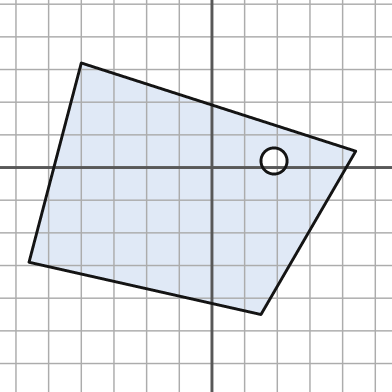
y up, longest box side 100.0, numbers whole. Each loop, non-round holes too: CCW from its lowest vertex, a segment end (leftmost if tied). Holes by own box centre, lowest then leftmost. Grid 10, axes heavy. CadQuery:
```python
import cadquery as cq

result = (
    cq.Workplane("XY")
    .moveTo(15.0, -45.0)
    .lineTo(44.0, 5.0)
    .lineTo(-40.0, 32.0)
    .lineTo(-56.0, -29.0)
    .close()
    .moveTo(19.0, 2.0)
    .circle(4.0)
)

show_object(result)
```